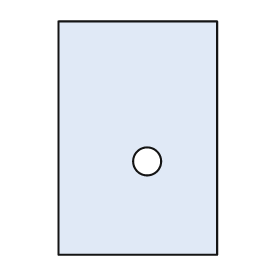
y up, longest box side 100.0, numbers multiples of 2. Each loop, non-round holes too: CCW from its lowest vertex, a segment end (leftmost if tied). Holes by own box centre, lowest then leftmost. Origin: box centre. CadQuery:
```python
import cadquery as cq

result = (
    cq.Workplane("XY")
    .moveTo(-34.0, -50.0)
    .lineTo(34.0, -50.0)
    .lineTo(34.0, 50.0)
    .lineTo(-34.0, 50.0)
    .close()
    .moveTo(4.0, -10.0)
    .circle(6.0)
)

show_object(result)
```